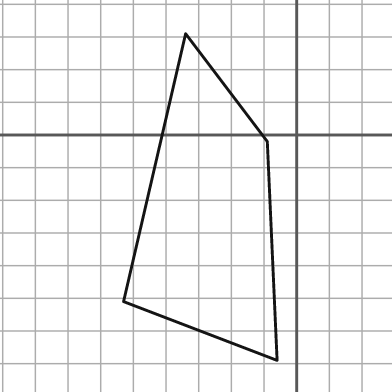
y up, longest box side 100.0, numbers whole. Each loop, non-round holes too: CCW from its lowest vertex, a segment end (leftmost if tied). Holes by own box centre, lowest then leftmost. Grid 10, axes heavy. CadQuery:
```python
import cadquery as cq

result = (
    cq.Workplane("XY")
    .moveTo(-6.0, -69.0)
    .lineTo(-9.0, -2.0)
    .lineTo(-34.0, 31.0)
    .lineTo(-53.0, -51.0)
    .close()
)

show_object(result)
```